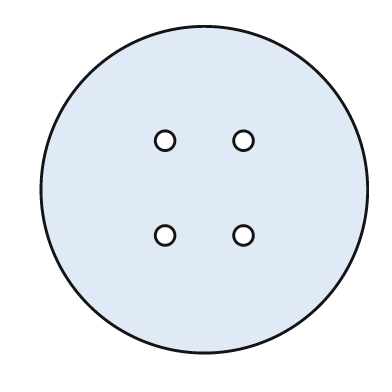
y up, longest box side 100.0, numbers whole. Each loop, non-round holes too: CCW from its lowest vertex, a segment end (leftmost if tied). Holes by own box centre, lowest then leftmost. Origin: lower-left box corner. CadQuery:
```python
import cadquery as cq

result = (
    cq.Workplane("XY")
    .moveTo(50.0, 50.0)
    .circle(50.0)
    .moveTo(38.0, 36.0)
    .circle(3.0)
    .moveTo(62.0, 36.0)
    .circle(3.0)
    .moveTo(38.0, 65.0)
    .circle(3.0)
    .moveTo(62.0, 65.0)
    .circle(3.0)
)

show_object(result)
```